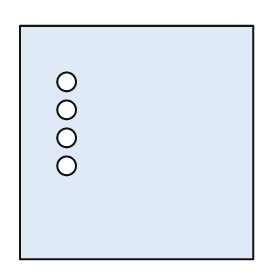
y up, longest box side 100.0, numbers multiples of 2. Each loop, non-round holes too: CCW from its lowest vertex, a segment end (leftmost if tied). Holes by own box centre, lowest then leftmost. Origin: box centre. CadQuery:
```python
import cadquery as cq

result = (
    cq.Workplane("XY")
    .moveTo(-50.0, -50.0)
    .lineTo(50.0, -50.0)
    .lineTo(50.0, 50.0)
    .lineTo(-50.0, 50.0)
    .close()
    .moveTo(-30.0, -10.0)
    .circle(4.0)
    .moveTo(-30.0, 2.0)
    .circle(4.0)
    .moveTo(-30.0, 14.0)
    .circle(4.0)
    .moveTo(-30.0, 26.0)
    .circle(4.0)
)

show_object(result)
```